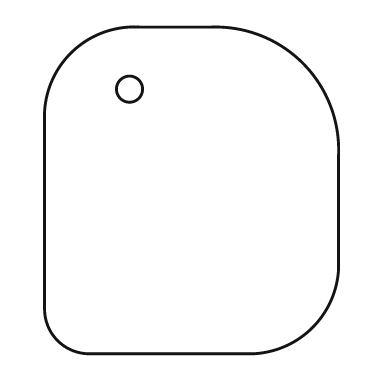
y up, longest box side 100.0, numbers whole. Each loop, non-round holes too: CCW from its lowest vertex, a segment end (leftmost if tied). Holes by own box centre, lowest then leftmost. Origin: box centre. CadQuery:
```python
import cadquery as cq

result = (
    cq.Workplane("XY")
    .moveTo(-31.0, -50.0)
    .lineTo(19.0, -50.0)
    .threePointArc((37.0, -42.0), (45.0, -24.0))
    .lineTo(45.0, 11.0)
    .threePointArc((34.0, 39.0), (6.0, 50.0))
    .lineTo(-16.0, 50.0)
    .threePointArc((-37.0, 42.0), (-45.0, 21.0))
    .lineTo(-45.0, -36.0)
    .threePointArc((-41.0, -46.0), (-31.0, -50.0))
    .close()
    .moveTo(-19.0, 31.0)
    .circle(4.0)
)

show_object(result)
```